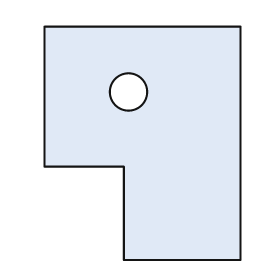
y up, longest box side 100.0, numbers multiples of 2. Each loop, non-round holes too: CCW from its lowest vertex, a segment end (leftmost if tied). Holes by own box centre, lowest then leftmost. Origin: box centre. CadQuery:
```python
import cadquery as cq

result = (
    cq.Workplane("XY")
    .moveTo(-8.0, -50.0)
    .lineTo(42.0, -50.0)
    .lineTo(42.0, 50.0)
    .lineTo(-42.0, 50.0)
    .lineTo(-42.0, -10.0)
    .lineTo(-8.0, -10.0)
    .close()
    .moveTo(-6.0, 22.0)
    .circle(8.0)
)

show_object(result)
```